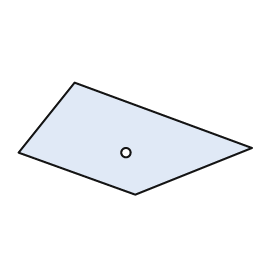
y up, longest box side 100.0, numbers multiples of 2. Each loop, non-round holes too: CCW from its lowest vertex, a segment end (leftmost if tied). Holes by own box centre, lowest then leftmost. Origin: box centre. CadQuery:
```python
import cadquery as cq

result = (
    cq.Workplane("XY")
    .moveTo(0.0, -24.0)
    .lineTo(50.0, -4.0)
    .lineTo(-26.0, 24.0)
    .lineTo(-50.0, -6.0)
    .close()
    .moveTo(-4.0, -6.0)
    .circle(2.0)
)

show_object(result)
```